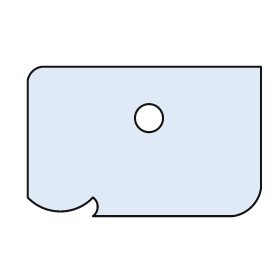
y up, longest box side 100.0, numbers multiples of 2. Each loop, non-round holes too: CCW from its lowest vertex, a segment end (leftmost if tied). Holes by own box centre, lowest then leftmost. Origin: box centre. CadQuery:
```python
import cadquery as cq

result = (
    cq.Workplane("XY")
    .moveTo(-22.0, -32.0)
    .lineTo(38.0, -32.0)
    .threePointArc((46.0, -28.0), (50.0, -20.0))
    .lineTo(50.0, 32.0)
    .lineTo(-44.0, 32.0)
    .threePointArc((-48.0, 30.0), (-50.0, 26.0))
    .lineTo(-50.0, -24.0)
    .threePointArc((-36.0, -30.0), (-22.0, -24.0))
    .threePointArc((-20.0, -28.0), (-22.0, -32.0))
    .close()
    .moveTo(2.0, 10.0)
    .circle(6.0)
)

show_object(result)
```